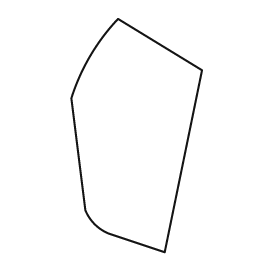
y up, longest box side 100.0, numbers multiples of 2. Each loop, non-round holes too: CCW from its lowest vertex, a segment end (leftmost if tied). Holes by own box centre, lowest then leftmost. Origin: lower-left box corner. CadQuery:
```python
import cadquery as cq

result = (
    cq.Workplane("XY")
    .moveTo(40.0, 0.0)
    .lineTo(56.0, 78.0)
    .lineTo(20.0, 100.0)
    .threePointArc((8.0, 84.0), (0.0, 66.0))
    .lineTo(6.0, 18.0)
    .threePointArc((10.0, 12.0), (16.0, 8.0))
    .close()
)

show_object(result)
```